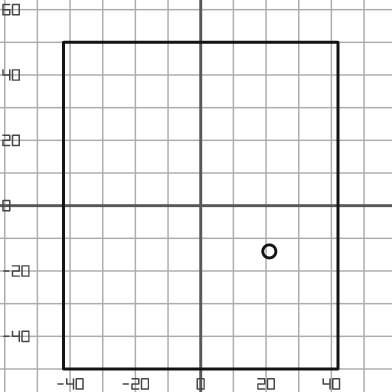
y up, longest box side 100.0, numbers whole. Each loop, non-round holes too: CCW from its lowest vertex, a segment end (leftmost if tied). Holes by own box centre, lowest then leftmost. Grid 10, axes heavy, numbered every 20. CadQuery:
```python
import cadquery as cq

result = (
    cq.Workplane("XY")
    .moveTo(-42.0, -50.0)
    .lineTo(42.0, -50.0)
    .lineTo(42.0, 50.0)
    .lineTo(-42.0, 50.0)
    .close()
    .moveTo(21.0, -14.0)
    .circle(2.0)
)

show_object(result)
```